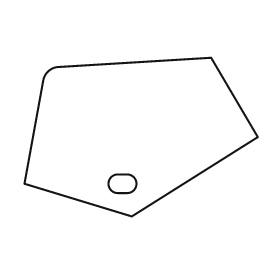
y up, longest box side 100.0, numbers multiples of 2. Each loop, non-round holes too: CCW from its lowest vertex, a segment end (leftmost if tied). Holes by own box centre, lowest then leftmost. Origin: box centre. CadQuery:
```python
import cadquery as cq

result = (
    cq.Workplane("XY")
    .moveTo(-4.0, -34.0)
    .lineTo(50.0, 0.0)
    .lineTo(30.0, 34.0)
    .lineTo(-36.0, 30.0)
    .threePointArc((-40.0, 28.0), (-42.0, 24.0))
    .lineTo(-50.0, -20.0)
    .close()
    .moveTo(-10.0, -24.0)
    .lineTo(-6.0, -24.0)
    .threePointArc((-2.0, -20.0), (-6.0, -16.0))
    .lineTo(-10.0, -16.0)
    .threePointArc((-14.0, -20.0), (-10.0, -24.0))
    .close()
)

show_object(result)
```